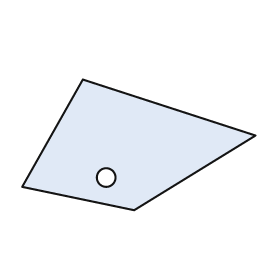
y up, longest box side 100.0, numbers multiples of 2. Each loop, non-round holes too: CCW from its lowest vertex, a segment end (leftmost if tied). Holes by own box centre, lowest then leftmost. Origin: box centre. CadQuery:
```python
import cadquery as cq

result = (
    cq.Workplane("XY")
    .moveTo(-2.0, -28.0)
    .lineTo(50.0, 4.0)
    .lineTo(-24.0, 28.0)
    .lineTo(-50.0, -18.0)
    .close()
    .moveTo(-14.0, -14.0)
    .circle(4.0)
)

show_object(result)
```